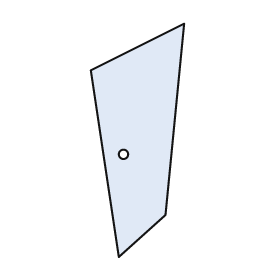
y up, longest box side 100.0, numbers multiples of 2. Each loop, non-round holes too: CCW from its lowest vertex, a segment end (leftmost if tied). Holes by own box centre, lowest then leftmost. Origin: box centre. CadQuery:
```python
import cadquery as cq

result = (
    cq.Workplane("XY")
    .moveTo(-8.0, -50.0)
    .lineTo(12.0, -32.0)
    .lineTo(20.0, 50.0)
    .lineTo(-20.0, 30.0)
    .close()
    .moveTo(-6.0, -6.0)
    .circle(2.0)
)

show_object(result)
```